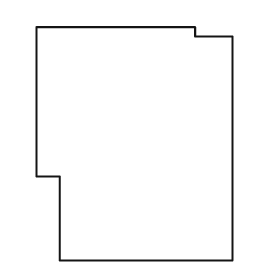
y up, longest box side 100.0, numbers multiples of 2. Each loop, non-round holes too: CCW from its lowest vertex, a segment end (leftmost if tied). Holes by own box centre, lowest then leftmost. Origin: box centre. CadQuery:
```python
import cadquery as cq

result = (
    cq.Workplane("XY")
    .moveTo(-32.0, -50.0)
    .lineTo(42.0, -50.0)
    .lineTo(42.0, 46.0)
    .lineTo(26.0, 46.0)
    .lineTo(26.0, 50.0)
    .lineTo(-42.0, 50.0)
    .lineTo(-42.0, -14.0)
    .lineTo(-32.0, -14.0)
    .close()
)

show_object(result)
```